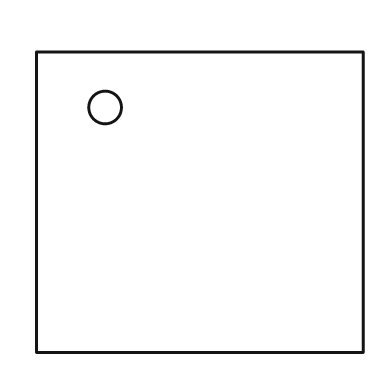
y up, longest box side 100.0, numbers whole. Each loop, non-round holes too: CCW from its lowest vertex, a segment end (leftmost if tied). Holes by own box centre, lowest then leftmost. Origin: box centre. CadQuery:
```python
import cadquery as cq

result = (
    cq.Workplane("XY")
    .moveTo(-50.0, -46.0)
    .lineTo(50.0, -46.0)
    .lineTo(50.0, 46.0)
    .lineTo(-50.0, 46.0)
    .close()
    .moveTo(-29.0, 29.0)
    .circle(5.0)
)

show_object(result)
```